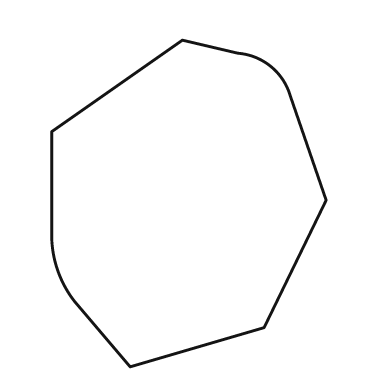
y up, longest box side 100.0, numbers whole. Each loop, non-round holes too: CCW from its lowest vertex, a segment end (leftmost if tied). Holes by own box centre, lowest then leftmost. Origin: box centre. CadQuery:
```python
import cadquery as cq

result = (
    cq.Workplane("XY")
    .moveTo(-18.0, -50.0)
    .lineTo(23.0, -38.0)
    .lineTo(42.0, 1.0)
    .lineTo(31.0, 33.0)
    .threePointArc((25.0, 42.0), (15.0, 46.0))
    .lineTo(-2.0, 50.0)
    .lineTo(-42.0, 22.0)
    .lineTo(-42.0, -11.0)
    .threePointArc((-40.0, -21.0), (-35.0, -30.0))
    .close()
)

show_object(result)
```